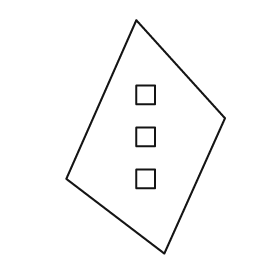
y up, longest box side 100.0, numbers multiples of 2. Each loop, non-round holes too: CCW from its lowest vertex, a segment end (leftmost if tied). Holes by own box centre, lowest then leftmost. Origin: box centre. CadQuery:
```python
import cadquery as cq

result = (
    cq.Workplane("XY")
    .moveTo(8.0, -50.0)
    .lineTo(34.0, 8.0)
    .lineTo(-4.0, 50.0)
    .lineTo(-34.0, -18.0)
    .close()
    .moveTo(-4.0, -22.0)
    .lineTo(4.0, -22.0)
    .lineTo(4.0, -14.0)
    .lineTo(-4.0, -14.0)
    .close()
    .moveTo(-4.0, -4.0)
    .lineTo(4.0, -4.0)
    .lineTo(4.0, 4.0)
    .lineTo(-4.0, 4.0)
    .close()
    .moveTo(-4.0, 14.0)
    .lineTo(4.0, 14.0)
    .lineTo(4.0, 22.0)
    .lineTo(-4.0, 22.0)
    .close()
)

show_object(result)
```